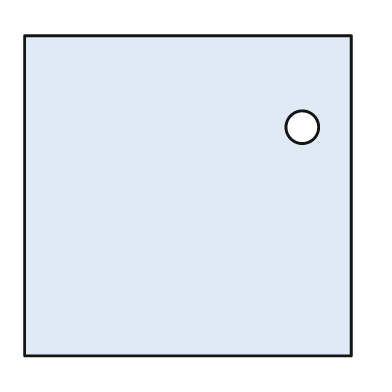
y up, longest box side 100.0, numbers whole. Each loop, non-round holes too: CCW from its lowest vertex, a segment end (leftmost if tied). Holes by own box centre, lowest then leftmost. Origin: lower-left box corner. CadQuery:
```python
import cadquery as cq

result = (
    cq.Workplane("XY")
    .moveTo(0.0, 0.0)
    .lineTo(100.0, 0.0)
    .lineTo(100.0, 98.0)
    .lineTo(0.0, 98.0)
    .close()
    .moveTo(85.0, 70.0)
    .circle(5.0)
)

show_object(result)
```